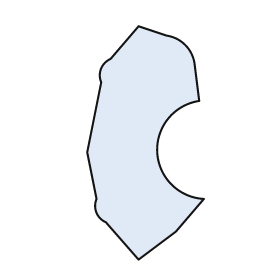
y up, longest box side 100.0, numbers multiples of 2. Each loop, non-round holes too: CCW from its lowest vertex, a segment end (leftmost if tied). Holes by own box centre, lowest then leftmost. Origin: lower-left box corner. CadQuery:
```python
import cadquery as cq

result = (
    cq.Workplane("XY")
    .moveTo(22.0, 0.0)
    .lineTo(38.0, 12.0)
    .lineTo(50.0, 26.0)
    .threePointArc((30.0, 46.0), (48.0, 68.0))
    .lineTo(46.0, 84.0)
    .threePointArc((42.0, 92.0), (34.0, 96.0))
    .lineTo(22.0, 100.0)
    .lineTo(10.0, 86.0)
    .threePointArc((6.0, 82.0), (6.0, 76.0))
    .lineTo(0.0, 46.0)
    .lineTo(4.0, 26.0)
    .threePointArc((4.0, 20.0), (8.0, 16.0))
    .close()
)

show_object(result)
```